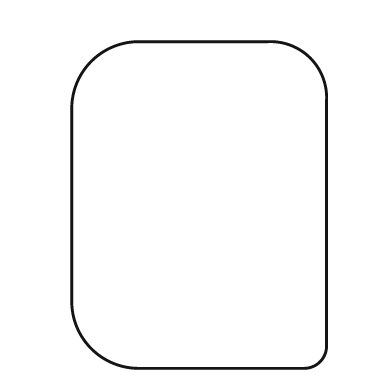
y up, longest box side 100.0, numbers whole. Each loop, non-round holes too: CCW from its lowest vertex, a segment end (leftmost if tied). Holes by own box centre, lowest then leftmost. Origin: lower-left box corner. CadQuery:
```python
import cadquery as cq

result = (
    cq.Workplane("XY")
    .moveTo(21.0, 0.0)
    .lineTo(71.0, 0.0)
    .threePointArc((76.0, 2.0), (78.0, 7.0))
    .lineTo(78.0, 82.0)
    .threePointArc((73.0, 95.0), (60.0, 100.0))
    .lineTo(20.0, 100.0)
    .threePointArc((6.0, 94.0), (0.0, 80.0))
    .lineTo(0.0, 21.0)
    .threePointArc((6.0, 6.0), (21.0, 0.0))
    .close()
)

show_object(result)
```